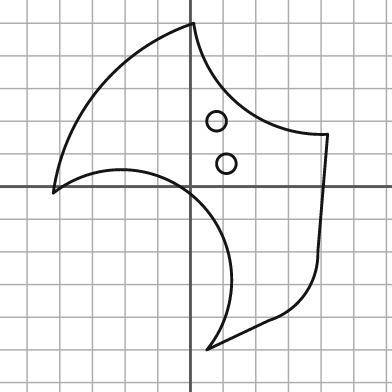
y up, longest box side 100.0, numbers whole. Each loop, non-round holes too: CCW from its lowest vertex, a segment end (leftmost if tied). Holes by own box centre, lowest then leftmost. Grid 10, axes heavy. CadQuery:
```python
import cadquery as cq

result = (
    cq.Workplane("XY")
    .moveTo(5.0, -50.0)
    .lineTo(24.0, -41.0)
    .threePointArc((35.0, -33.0), (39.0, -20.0))
    .lineTo(42.0, 16.0)
    .threePointArc((15.0, 25.0), (1.0, 50.0))
    .threePointArc((-28.0, 30.0), (-42.0, -2.0))
    .threePointArc((3.0, -5.0), (5.0, -50.0))
    .close()
    .moveTo(11.0, 7.0)
    .circle(3.0)
    .moveTo(8.0, 20.0)
    .circle(3.0)
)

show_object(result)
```